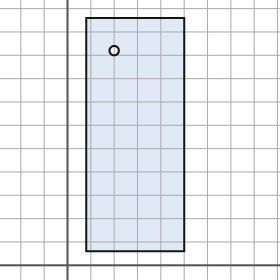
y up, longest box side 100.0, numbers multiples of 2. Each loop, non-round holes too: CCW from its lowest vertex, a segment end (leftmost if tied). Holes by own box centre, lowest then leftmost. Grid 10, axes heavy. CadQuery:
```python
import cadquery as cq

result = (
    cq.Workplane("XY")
    .moveTo(8.0, 6.0)
    .lineTo(50.0, 6.0)
    .lineTo(50.0, 106.0)
    .lineTo(8.0, 106.0)
    .close()
    .moveTo(20.0, 92.0)
    .circle(2.0)
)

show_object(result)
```